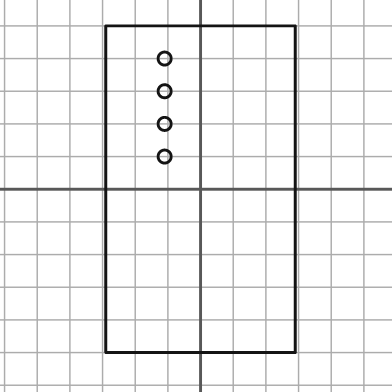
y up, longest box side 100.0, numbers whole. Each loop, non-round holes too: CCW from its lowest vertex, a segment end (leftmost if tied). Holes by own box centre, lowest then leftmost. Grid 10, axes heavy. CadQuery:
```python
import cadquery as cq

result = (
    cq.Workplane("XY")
    .moveTo(-29.0, -50.0)
    .lineTo(29.0, -50.0)
    .lineTo(29.0, 50.0)
    .lineTo(-29.0, 50.0)
    .close()
    .moveTo(-11.0, 10.0)
    .circle(2.0)
    .moveTo(-11.0, 20.0)
    .circle(2.0)
    .moveTo(-11.0, 30.0)
    .circle(2.0)
    .moveTo(-11.0, 40.0)
    .circle(2.0)
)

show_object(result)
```